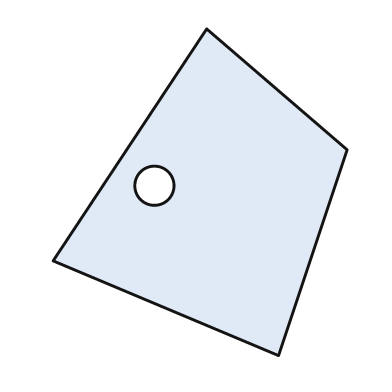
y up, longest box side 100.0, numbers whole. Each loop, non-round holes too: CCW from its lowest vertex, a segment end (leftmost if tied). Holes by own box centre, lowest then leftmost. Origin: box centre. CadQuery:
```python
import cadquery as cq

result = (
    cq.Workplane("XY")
    .moveTo(24.0, -50.0)
    .lineTo(45.0, 13.0)
    .lineTo(2.0, 50.0)
    .lineTo(-45.0, -21.0)
    .close()
    .moveTo(-14.0, 2.0)
    .circle(6.0)
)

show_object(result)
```